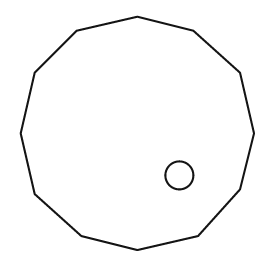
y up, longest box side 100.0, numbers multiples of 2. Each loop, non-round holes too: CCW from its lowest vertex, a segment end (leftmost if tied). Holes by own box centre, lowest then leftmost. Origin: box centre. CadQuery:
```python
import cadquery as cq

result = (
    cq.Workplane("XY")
    .moveTo(0.0, -50.0)
    .lineTo(26.0, -44.0)
    .lineTo(44.0, -24.0)
    .lineTo(50.0, 0.0)
    .lineTo(44.0, 26.0)
    .lineTo(24.0, 44.0)
    .lineTo(0.0, 50.0)
    .lineTo(-26.0, 44.0)
    .lineTo(-44.0, 26.0)
    .lineTo(-50.0, 0.0)
    .lineTo(-44.0, -26.0)
    .lineTo(-24.0, -44.0)
    .close()
    .moveTo(18.0, -18.0)
    .circle(6.0)
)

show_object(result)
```